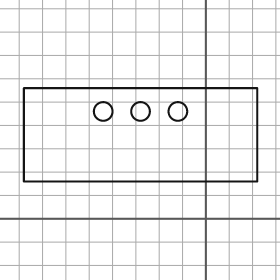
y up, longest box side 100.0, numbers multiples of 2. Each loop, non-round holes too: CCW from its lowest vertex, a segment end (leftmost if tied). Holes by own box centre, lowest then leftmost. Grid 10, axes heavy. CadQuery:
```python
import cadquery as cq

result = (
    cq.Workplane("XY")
    .moveTo(-78.0, 16.0)
    .lineTo(22.0, 16.0)
    .lineTo(22.0, 56.0)
    .lineTo(-78.0, 56.0)
    .close()
    .moveTo(-44.0, 46.0)
    .circle(4.0)
    .moveTo(-28.0, 46.0)
    .circle(4.0)
    .moveTo(-12.0, 46.0)
    .circle(4.0)
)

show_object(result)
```